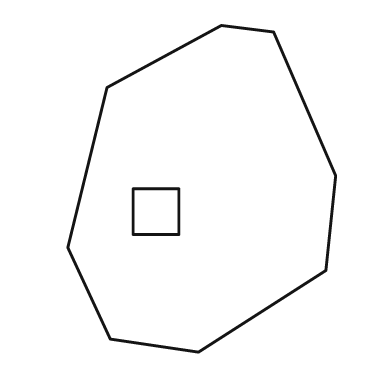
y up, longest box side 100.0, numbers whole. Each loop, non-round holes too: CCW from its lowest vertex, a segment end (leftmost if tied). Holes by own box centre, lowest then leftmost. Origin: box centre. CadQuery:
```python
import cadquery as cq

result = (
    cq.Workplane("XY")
    .moveTo(-1.0, -50.0)
    .lineTo(38.0, -25.0)
    .lineTo(41.0, 4.0)
    .lineTo(22.0, 48.0)
    .lineTo(6.0, 50.0)
    .lineTo(-29.0, 31.0)
    .lineTo(-41.0, -18.0)
    .lineTo(-28.0, -46.0)
    .close()
    .moveTo(-21.0, -14.0)
    .lineTo(-7.0, -14.0)
    .lineTo(-7.0, 0.0)
    .lineTo(-21.0, 0.0)
    .close()
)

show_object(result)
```